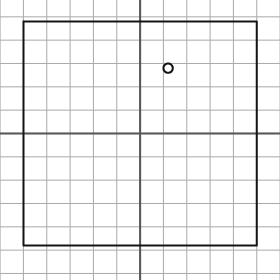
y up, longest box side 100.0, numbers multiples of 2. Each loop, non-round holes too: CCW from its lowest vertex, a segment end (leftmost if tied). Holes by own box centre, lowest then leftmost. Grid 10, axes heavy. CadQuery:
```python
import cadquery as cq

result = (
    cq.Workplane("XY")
    .moveTo(-50.0, -48.0)
    .lineTo(50.0, -48.0)
    .lineTo(50.0, 48.0)
    .lineTo(-50.0, 48.0)
    .close()
    .moveTo(12.0, 28.0)
    .circle(2.0)
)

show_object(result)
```